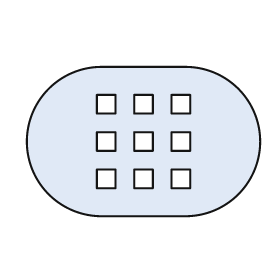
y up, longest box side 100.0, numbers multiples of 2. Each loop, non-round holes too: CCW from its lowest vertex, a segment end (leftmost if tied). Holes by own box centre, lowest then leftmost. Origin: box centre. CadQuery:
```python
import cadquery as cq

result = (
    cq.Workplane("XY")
    .moveTo(-18.0, -32.0)
    .lineTo(18.0, -32.0)
    .threePointArc((50.0, 0.0), (18.0, 32.0))
    .lineTo(-18.0, 32.0)
    .threePointArc((-50.0, 0.0), (-18.0, -32.0))
    .close()
    .moveTo(-20.0, -20.0)
    .lineTo(-12.0, -20.0)
    .lineTo(-12.0, -12.0)
    .lineTo(-20.0, -12.0)
    .close()
    .moveTo(-4.0, -20.0)
    .lineTo(4.0, -20.0)
    .lineTo(4.0, -12.0)
    .lineTo(-4.0, -12.0)
    .close()
    .moveTo(12.0, -20.0)
    .lineTo(20.0, -20.0)
    .lineTo(20.0, -12.0)
    .lineTo(12.0, -12.0)
    .close()
    .moveTo(-20.0, -4.0)
    .lineTo(-12.0, -4.0)
    .lineTo(-12.0, 4.0)
    .lineTo(-20.0, 4.0)
    .close()
    .moveTo(-4.0, -4.0)
    .lineTo(4.0, -4.0)
    .lineTo(4.0, 4.0)
    .lineTo(-4.0, 4.0)
    .close()
    .moveTo(12.0, -4.0)
    .lineTo(20.0, -4.0)
    .lineTo(20.0, 4.0)
    .lineTo(12.0, 4.0)
    .close()
    .moveTo(-20.0, 12.0)
    .lineTo(-12.0, 12.0)
    .lineTo(-12.0, 20.0)
    .lineTo(-20.0, 20.0)
    .close()
    .moveTo(-4.0, 12.0)
    .lineTo(4.0, 12.0)
    .lineTo(4.0, 20.0)
    .lineTo(-4.0, 20.0)
    .close()
    .moveTo(12.0, 12.0)
    .lineTo(20.0, 12.0)
    .lineTo(20.0, 20.0)
    .lineTo(12.0, 20.0)
    .close()
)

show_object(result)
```